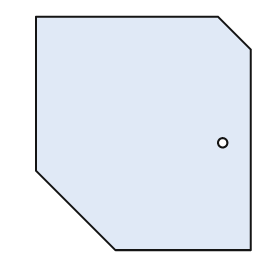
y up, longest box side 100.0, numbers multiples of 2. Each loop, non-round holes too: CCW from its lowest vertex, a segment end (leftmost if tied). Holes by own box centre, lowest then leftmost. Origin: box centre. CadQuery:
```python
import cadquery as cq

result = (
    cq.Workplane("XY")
    .moveTo(-12.0, -50.0)
    .lineTo(46.0, -50.0)
    .lineTo(46.0, 36.0)
    .lineTo(32.0, 50.0)
    .lineTo(-46.0, 50.0)
    .lineTo(-46.0, -16.0)
    .close()
    .moveTo(34.0, -4.0)
    .circle(2.0)
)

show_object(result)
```